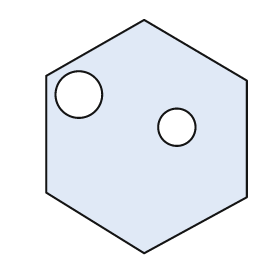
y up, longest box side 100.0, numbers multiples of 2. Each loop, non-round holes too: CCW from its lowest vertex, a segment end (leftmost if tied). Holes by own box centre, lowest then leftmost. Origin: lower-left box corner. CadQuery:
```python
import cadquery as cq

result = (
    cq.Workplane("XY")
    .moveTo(42.0, 0.0)
    .lineTo(86.0, 24.0)
    .lineTo(86.0, 74.0)
    .lineTo(42.0, 100.0)
    .lineTo(0.0, 76.0)
    .lineTo(0.0, 26.0)
    .close()
    .moveTo(56.0, 54.0)
    .circle(8.0)
    .moveTo(14.0, 68.0)
    .circle(10.0)
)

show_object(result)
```